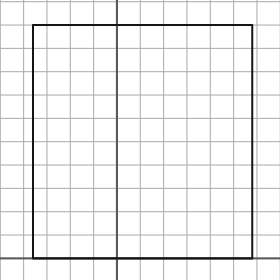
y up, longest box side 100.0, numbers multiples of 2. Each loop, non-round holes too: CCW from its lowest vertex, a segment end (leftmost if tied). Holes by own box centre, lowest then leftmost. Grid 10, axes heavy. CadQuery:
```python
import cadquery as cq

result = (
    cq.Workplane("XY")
    .moveTo(-36.0, 0.0)
    .lineTo(58.0, 0.0)
    .lineTo(58.0, 100.0)
    .lineTo(-36.0, 100.0)
    .close()
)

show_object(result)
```